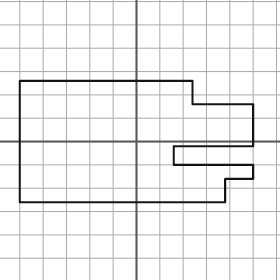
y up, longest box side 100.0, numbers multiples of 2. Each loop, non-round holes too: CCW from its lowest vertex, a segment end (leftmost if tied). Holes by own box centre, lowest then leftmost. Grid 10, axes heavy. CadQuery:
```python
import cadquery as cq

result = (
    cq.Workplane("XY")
    .moveTo(-50.0, -26.0)
    .lineTo(38.0, -26.0)
    .lineTo(38.0, -16.0)
    .lineTo(50.0, -16.0)
    .lineTo(50.0, -10.0)
    .lineTo(16.0, -10.0)
    .lineTo(16.0, -2.0)
    .lineTo(50.0, -2.0)
    .lineTo(50.0, 16.0)
    .lineTo(24.0, 16.0)
    .lineTo(24.0, 26.0)
    .lineTo(-50.0, 26.0)
    .close()
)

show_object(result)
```